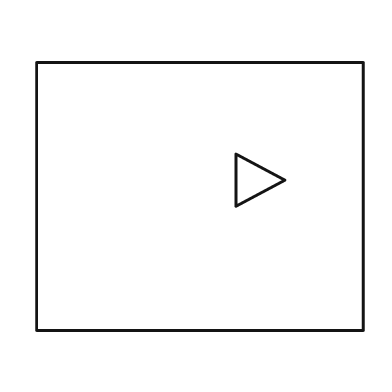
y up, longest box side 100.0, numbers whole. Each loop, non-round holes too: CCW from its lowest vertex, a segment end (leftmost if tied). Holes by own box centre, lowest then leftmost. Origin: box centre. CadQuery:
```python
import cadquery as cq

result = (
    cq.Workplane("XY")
    .moveTo(-50.0, -41.0)
    .lineTo(50.0, -41.0)
    .lineTo(50.0, 41.0)
    .lineTo(-50.0, 41.0)
    .close()
    .moveTo(11.0, -3.0)
    .lineTo(26.0, 5.0)
    .lineTo(11.0, 13.0)
    .close()
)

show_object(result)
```